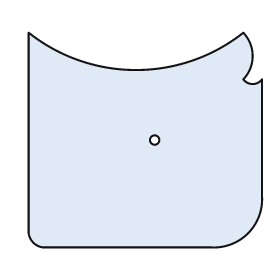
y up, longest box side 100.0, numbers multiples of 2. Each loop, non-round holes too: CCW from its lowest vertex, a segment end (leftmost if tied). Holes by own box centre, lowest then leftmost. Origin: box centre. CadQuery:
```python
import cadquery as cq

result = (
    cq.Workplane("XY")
    .moveTo(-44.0, -46.0)
    .lineTo(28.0, -46.0)
    .threePointArc((44.0, -40.0), (50.0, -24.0))
    .lineTo(50.0, 26.0)
    .threePointArc((46.0, 24.0), (42.0, 26.0))
    .threePointArc((46.0, 36.0), (42.0, 46.0))
    .threePointArc((-4.0, 30.0), (-50.0, 46.0))
    .lineTo(-50.0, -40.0)
    .threePointArc((-48.0, -44.0), (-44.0, -46.0))
    .close()
    .moveTo(4.0, 0.0)
    .circle(2.0)
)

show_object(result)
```